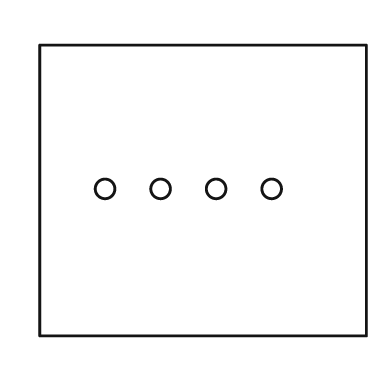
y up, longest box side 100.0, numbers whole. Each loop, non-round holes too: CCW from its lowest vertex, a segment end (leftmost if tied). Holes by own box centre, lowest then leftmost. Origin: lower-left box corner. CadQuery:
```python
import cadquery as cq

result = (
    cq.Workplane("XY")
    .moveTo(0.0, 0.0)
    .lineTo(100.0, 0.0)
    .lineTo(100.0, 89.0)
    .lineTo(0.0, 89.0)
    .close()
    .moveTo(20.0, 45.0)
    .circle(3.0)
    .moveTo(37.0, 45.0)
    .circle(3.0)
    .moveTo(54.0, 45.0)
    .circle(3.0)
    .moveTo(71.0, 45.0)
    .circle(3.0)
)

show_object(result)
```